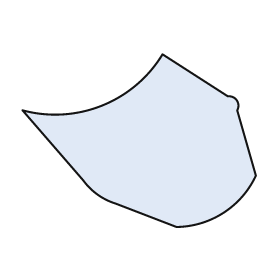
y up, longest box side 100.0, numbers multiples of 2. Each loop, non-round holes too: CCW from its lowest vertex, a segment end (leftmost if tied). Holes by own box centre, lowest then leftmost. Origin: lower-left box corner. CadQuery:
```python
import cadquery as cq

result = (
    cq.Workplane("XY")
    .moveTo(66.0, 0.0)
    .threePointArc((86.0, 6.0), (100.0, 22.0))
    .lineTo(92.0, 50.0)
    .threePointArc((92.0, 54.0), (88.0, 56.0))
    .lineTo(60.0, 74.0)
    .threePointArc((34.0, 52.0), (0.0, 50.0))
    .lineTo(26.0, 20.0)
    .threePointArc((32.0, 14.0), (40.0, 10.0))
    .close()
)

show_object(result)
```